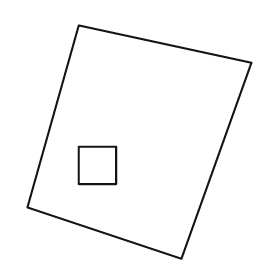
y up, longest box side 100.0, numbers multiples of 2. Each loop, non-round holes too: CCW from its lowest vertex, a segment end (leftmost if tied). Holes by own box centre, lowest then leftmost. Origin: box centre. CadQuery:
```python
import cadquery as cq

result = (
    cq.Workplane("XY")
    .moveTo(18.0, -50.0)
    .lineTo(48.0, 34.0)
    .lineTo(-26.0, 50.0)
    .lineTo(-48.0, -28.0)
    .close()
    .moveTo(-26.0, -18.0)
    .lineTo(-10.0, -18.0)
    .lineTo(-10.0, -2.0)
    .lineTo(-26.0, -2.0)
    .close()
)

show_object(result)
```